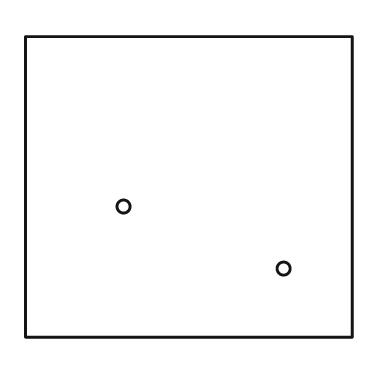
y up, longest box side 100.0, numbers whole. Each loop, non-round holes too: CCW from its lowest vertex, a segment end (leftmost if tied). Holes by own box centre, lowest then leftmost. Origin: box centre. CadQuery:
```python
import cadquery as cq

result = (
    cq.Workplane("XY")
    .moveTo(-50.0, -46.0)
    .lineTo(50.0, -46.0)
    .lineTo(50.0, 46.0)
    .lineTo(-50.0, 46.0)
    .close()
    .moveTo(29.0, -25.0)
    .circle(2.0)
    .moveTo(-20.0, -6.0)
    .circle(2.0)
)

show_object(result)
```